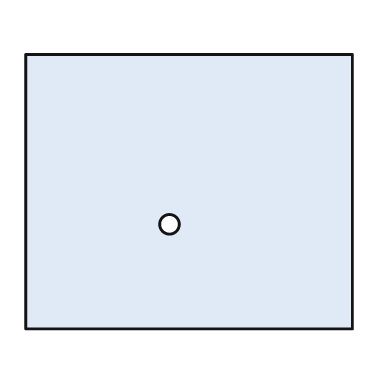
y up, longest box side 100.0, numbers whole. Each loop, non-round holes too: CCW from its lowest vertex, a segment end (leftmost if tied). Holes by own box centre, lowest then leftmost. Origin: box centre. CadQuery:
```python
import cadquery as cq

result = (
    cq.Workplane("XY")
    .moveTo(-50.0, -42.0)
    .lineTo(50.0, -42.0)
    .lineTo(50.0, 42.0)
    .lineTo(-50.0, 42.0)
    .close()
    .moveTo(-6.0, -10.0)
    .circle(3.0)
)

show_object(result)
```